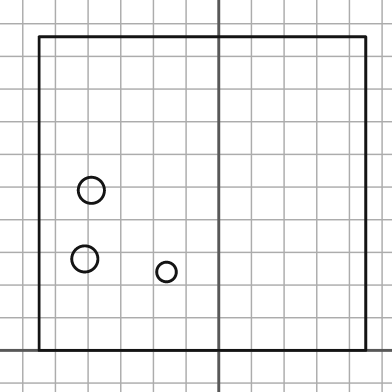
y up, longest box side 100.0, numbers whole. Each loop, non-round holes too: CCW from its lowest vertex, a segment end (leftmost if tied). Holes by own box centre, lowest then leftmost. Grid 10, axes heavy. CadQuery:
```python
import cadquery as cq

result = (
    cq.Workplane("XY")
    .moveTo(-55.0, 0.0)
    .lineTo(45.0, 0.0)
    .lineTo(45.0, 96.0)
    .lineTo(-55.0, 96.0)
    .close()
    .moveTo(-16.0, 24.0)
    .circle(3.0)
    .moveTo(-41.0, 28.0)
    .circle(4.0)
    .moveTo(-39.0, 49.0)
    .circle(4.0)
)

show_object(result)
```